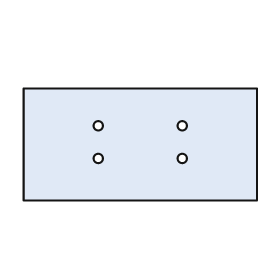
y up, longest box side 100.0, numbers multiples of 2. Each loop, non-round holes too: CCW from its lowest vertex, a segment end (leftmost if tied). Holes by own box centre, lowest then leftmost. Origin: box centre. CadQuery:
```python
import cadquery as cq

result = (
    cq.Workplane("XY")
    .moveTo(-50.0, -24.0)
    .lineTo(50.0, -24.0)
    .lineTo(50.0, 24.0)
    .lineTo(-50.0, 24.0)
    .close()
    .moveTo(-18.0, -6.0)
    .circle(2.0)
    .moveTo(18.0, -6.0)
    .circle(2.0)
    .moveTo(-18.0, 8.0)
    .circle(2.0)
    .moveTo(18.0, 8.0)
    .circle(2.0)
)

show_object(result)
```